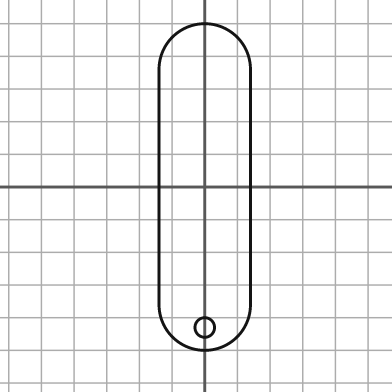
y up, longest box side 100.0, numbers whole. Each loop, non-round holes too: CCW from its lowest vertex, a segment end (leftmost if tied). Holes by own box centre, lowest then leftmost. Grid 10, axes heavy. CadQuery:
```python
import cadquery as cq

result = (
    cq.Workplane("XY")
    .moveTo(-14.0, -36.0)
    .threePointArc((0.0, -50.0), (14.0, -36.0))
    .lineTo(14.0, 36.0)
    .threePointArc((0.0, 50.0), (-14.0, 36.0))
    .close()
    .moveTo(0.0, -43.0)
    .circle(3.0)
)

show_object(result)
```